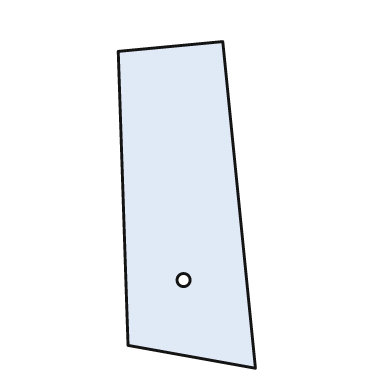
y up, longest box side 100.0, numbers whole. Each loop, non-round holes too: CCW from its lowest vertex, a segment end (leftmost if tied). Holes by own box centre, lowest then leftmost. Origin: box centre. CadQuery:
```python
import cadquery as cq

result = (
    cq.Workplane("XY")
    .moveTo(21.0, -50.0)
    .lineTo(11.0, 50.0)
    .lineTo(-21.0, 47.0)
    .lineTo(-18.0, -43.0)
    .close()
    .moveTo(-1.0, -23.0)
    .circle(2.0)
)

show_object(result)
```